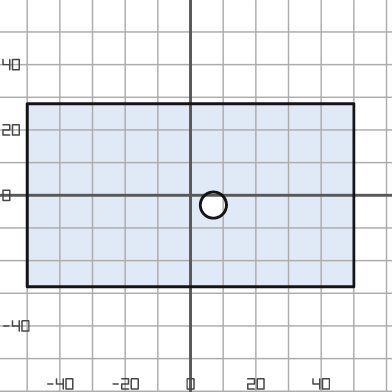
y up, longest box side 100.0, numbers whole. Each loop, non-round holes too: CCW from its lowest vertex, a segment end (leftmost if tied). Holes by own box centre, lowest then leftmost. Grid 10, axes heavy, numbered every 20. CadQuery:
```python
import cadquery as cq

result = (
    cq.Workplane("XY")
    .moveTo(-50.0, -28.0)
    .lineTo(50.0, -28.0)
    .lineTo(50.0, 28.0)
    .lineTo(-50.0, 28.0)
    .close()
    .moveTo(7.0, -3.0)
    .circle(4.0)
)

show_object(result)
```